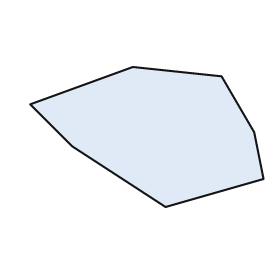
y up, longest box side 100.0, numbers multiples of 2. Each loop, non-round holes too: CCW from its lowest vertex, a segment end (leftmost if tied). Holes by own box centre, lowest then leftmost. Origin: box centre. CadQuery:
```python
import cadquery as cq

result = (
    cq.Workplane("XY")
    .moveTo(8.0, -30.0)
    .lineTo(50.0, -18.0)
    .lineTo(46.0, 2.0)
    .lineTo(32.0, 26.0)
    .lineTo(-6.0, 30.0)
    .lineTo(-50.0, 14.0)
    .lineTo(-32.0, -4.0)
    .close()
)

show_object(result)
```